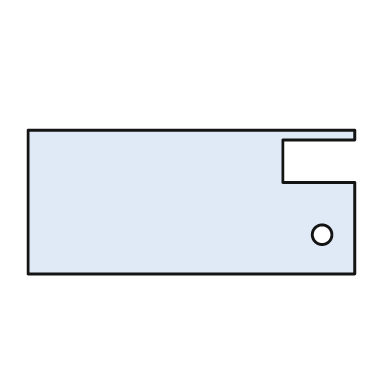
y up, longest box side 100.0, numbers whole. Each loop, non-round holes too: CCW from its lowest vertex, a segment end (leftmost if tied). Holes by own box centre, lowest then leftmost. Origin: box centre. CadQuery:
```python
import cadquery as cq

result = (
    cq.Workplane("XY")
    .moveTo(-50.0, -22.0)
    .lineTo(50.0, -22.0)
    .lineTo(50.0, 6.0)
    .lineTo(28.0, 6.0)
    .lineTo(28.0, 19.0)
    .lineTo(50.0, 19.0)
    .lineTo(50.0, 22.0)
    .lineTo(-50.0, 22.0)
    .close()
    .moveTo(40.0, -10.0)
    .circle(3.0)
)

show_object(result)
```